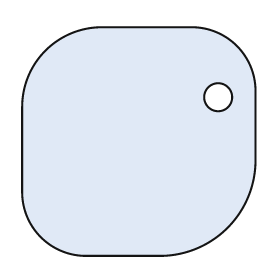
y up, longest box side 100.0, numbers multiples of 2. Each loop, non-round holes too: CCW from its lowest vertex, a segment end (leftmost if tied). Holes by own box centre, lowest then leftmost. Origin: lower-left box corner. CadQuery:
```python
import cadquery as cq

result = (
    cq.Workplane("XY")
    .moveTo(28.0, 0.0)
    .lineTo(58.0, 0.0)
    .threePointArc((88.0, 12.0), (100.0, 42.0))
    .lineTo(100.0, 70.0)
    .threePointArc((92.0, 90.0), (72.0, 98.0))
    .lineTo(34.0, 98.0)
    .threePointArc((10.0, 88.0), (0.0, 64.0))
    .lineTo(0.0, 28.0)
    .threePointArc((8.0, 8.0), (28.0, 0.0))
    .close()
    .moveTo(84.0, 68.0)
    .circle(6.0)
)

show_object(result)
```